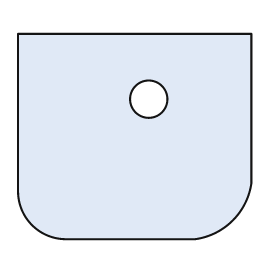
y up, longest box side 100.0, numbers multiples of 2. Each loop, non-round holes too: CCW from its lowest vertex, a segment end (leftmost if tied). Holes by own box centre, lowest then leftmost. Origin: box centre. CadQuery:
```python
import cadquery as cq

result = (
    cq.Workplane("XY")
    .moveTo(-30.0, -44.0)
    .lineTo(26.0, -44.0)
    .threePointArc((42.0, -36.0), (50.0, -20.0))
    .lineTo(50.0, 44.0)
    .lineTo(-50.0, 44.0)
    .lineTo(-50.0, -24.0)
    .threePointArc((-44.0, -38.0), (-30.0, -44.0))
    .close()
    .moveTo(6.0, 16.0)
    .circle(8.0)
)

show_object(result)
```